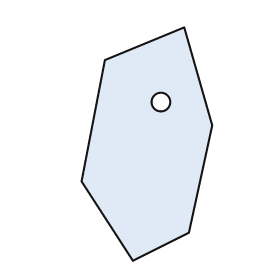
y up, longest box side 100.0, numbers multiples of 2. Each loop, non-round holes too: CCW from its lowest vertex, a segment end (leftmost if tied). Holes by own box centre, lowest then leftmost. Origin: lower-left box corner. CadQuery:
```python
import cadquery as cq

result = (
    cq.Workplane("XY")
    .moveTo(22.0, 0.0)
    .lineTo(46.0, 12.0)
    .lineTo(56.0, 58.0)
    .lineTo(44.0, 100.0)
    .lineTo(10.0, 86.0)
    .lineTo(0.0, 34.0)
    .close()
    .moveTo(34.0, 68.0)
    .circle(4.0)
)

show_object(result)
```